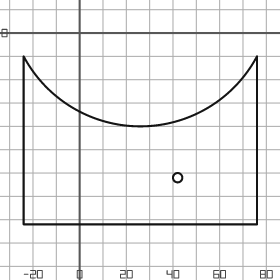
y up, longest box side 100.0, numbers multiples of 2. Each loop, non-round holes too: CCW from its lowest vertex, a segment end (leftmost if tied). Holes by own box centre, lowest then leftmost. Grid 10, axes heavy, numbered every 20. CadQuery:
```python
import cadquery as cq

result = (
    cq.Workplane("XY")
    .moveTo(-24.0, -82.0)
    .lineTo(76.0, -82.0)
    .lineTo(76.0, -10.0)
    .threePointArc((26.0, -40.0), (-24.0, -10.0))
    .close()
    .moveTo(42.0, -62.0)
    .circle(2.0)
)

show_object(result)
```